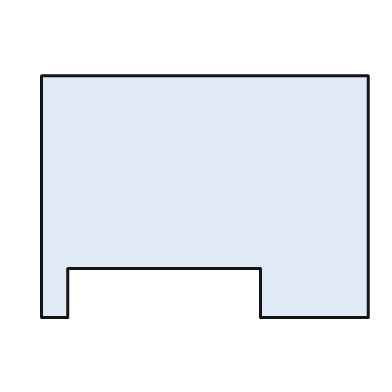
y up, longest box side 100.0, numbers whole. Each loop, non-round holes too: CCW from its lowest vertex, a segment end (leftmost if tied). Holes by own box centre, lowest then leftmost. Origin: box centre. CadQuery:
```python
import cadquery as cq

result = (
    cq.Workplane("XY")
    .moveTo(-50.0, -37.0)
    .lineTo(-42.0, -37.0)
    .lineTo(-42.0, -22.0)
    .lineTo(17.0, -22.0)
    .lineTo(17.0, -37.0)
    .lineTo(50.0, -37.0)
    .lineTo(50.0, 37.0)
    .lineTo(-50.0, 37.0)
    .close()
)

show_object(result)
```